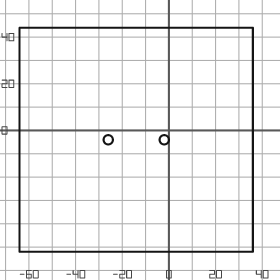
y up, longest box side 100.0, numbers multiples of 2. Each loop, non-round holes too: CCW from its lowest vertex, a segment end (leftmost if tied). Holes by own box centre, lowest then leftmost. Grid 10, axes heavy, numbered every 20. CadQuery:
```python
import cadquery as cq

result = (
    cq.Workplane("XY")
    .moveTo(-64.0, -52.0)
    .lineTo(36.0, -52.0)
    .lineTo(36.0, 44.0)
    .lineTo(-64.0, 44.0)
    .close()
    .moveTo(-26.0, -4.0)
    .circle(2.0)
    .moveTo(-2.0, -4.0)
    .circle(2.0)
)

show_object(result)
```